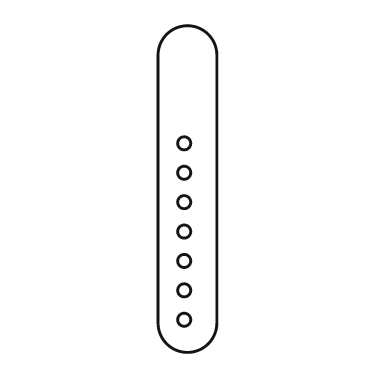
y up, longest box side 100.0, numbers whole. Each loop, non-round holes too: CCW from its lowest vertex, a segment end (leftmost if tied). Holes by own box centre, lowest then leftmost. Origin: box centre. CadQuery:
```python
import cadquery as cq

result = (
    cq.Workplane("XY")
    .moveTo(-9.0, -41.0)
    .threePointArc((0.0, -50.0), (9.0, -41.0))
    .lineTo(9.0, 41.0)
    .threePointArc((0.0, 50.0), (-9.0, 41.0))
    .close()
    .moveTo(-1.0, -40.0)
    .circle(2.0)
    .moveTo(-1.0, -31.0)
    .circle(2.0)
    .moveTo(-1.0, -22.0)
    .circle(2.0)
    .moveTo(-1.0, -13.0)
    .circle(2.0)
    .moveTo(-1.0, -4.0)
    .circle(2.0)
    .moveTo(-1.0, 5.0)
    .circle(2.0)
    .moveTo(-1.0, 14.0)
    .circle(2.0)
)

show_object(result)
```